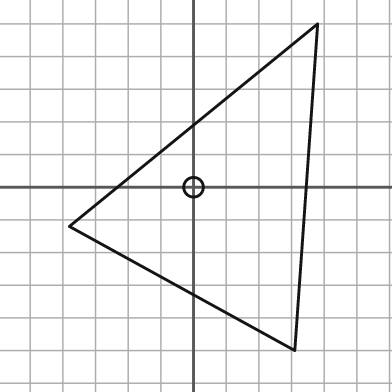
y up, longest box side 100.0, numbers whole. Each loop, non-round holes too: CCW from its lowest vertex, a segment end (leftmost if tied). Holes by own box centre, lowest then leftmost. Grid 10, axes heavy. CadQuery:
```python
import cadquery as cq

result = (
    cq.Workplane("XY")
    .moveTo(31.0, -50.0)
    .lineTo(38.0, 50.0)
    .lineTo(-38.0, -12.0)
    .close()
    .moveTo(0.0, 0.0)
    .circle(3.0)
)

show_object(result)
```